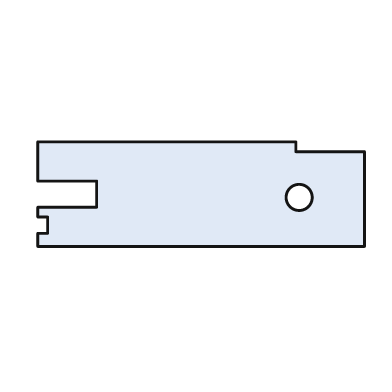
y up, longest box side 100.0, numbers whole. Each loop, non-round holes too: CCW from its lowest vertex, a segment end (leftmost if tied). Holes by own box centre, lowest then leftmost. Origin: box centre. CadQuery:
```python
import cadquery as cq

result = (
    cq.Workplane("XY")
    .moveTo(-50.0, -16.0)
    .lineTo(50.0, -16.0)
    .lineTo(50.0, 13.0)
    .lineTo(29.0, 13.0)
    .lineTo(29.0, 16.0)
    .lineTo(-50.0, 16.0)
    .lineTo(-50.0, 4.0)
    .lineTo(-32.0, 4.0)
    .lineTo(-32.0, -4.0)
    .lineTo(-50.0, -4.0)
    .lineTo(-50.0, -7.0)
    .lineTo(-47.0, -7.0)
    .lineTo(-47.0, -12.0)
    .lineTo(-50.0, -12.0)
    .close()
    .moveTo(30.0, -1.0)
    .circle(4.0)
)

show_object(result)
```